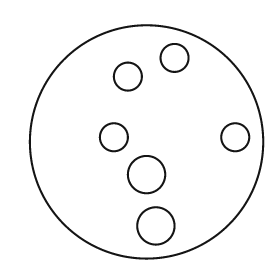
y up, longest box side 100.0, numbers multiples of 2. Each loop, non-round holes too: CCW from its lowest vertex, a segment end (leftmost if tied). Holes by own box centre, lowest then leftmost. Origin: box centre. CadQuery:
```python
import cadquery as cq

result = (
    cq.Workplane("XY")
    .moveTo(0.0, 0.0)
    .circle(50.0)
    .moveTo(4.0, -36.0)
    .circle(8.0)
    .moveTo(0.0, -14.0)
    .circle(8.0)
    .moveTo(-14.0, 2.0)
    .circle(6.0)
    .moveTo(38.0, 2.0)
    .circle(6.0)
    .moveTo(-8.0, 28.0)
    .circle(6.0)
    .moveTo(12.0, 36.0)
    .circle(6.0)
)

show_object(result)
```